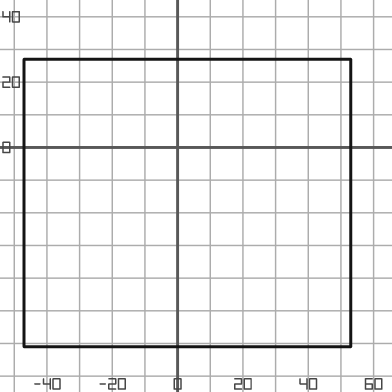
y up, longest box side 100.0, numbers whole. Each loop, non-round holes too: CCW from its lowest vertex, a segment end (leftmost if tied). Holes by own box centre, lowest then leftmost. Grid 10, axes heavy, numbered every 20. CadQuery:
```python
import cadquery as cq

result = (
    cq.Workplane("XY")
    .moveTo(-47.0, -61.0)
    .lineTo(53.0, -61.0)
    .lineTo(53.0, 27.0)
    .lineTo(-47.0, 27.0)
    .close()
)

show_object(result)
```